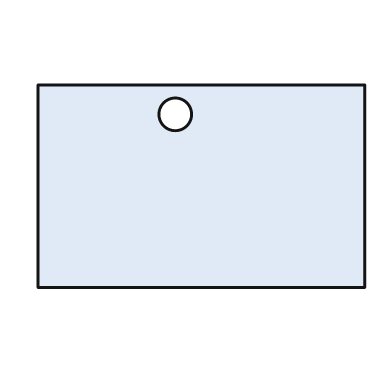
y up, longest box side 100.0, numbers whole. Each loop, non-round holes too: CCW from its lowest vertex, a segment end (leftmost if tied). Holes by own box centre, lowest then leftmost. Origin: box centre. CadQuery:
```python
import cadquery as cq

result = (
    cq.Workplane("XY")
    .moveTo(-50.0, -31.0)
    .lineTo(50.0, -31.0)
    .lineTo(50.0, 31.0)
    .lineTo(-50.0, 31.0)
    .close()
    .moveTo(-8.0, 22.0)
    .circle(5.0)
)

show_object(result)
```